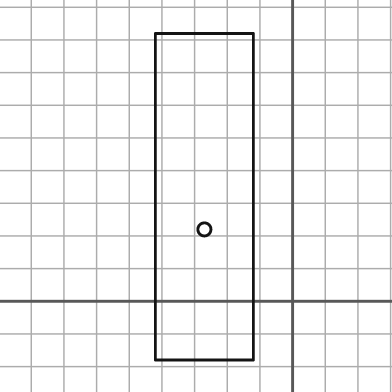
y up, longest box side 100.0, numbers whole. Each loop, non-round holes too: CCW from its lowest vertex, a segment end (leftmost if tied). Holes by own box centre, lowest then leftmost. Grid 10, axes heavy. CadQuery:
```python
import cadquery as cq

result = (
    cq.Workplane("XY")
    .moveTo(-42.0, -18.0)
    .lineTo(-12.0, -18.0)
    .lineTo(-12.0, 82.0)
    .lineTo(-42.0, 82.0)
    .close()
    .moveTo(-27.0, 22.0)
    .circle(2.0)
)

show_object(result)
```